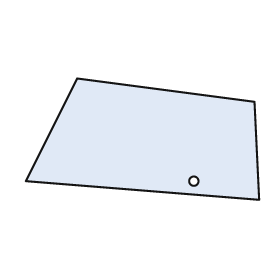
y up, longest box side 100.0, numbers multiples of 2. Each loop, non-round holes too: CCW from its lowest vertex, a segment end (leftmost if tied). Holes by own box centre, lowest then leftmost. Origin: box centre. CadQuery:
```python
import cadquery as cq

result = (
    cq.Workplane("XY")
    .moveTo(50.0, -26.0)
    .lineTo(48.0, 16.0)
    .lineTo(-28.0, 26.0)
    .lineTo(-50.0, -18.0)
    .close()
    .moveTo(22.0, -18.0)
    .circle(2.0)
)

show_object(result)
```